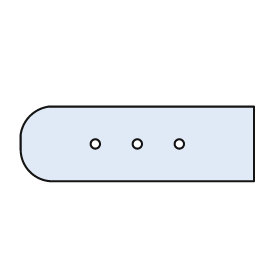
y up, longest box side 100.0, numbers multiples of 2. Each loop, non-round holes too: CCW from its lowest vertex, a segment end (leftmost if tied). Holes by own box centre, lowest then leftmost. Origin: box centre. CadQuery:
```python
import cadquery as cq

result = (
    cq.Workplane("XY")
    .moveTo(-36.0, -16.0)
    .lineTo(50.0, -16.0)
    .lineTo(50.0, 16.0)
    .lineTo(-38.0, 16.0)
    .threePointArc((-46.0, 12.0), (-50.0, 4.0))
    .lineTo(-50.0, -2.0)
    .threePointArc((-46.0, -12.0), (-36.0, -16.0))
    .close()
    .moveTo(-18.0, 0.0)
    .circle(2.0)
    .moveTo(0.0, 0.0)
    .circle(2.0)
    .moveTo(18.0, 0.0)
    .circle(2.0)
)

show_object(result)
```